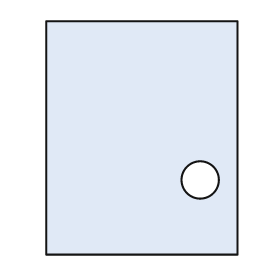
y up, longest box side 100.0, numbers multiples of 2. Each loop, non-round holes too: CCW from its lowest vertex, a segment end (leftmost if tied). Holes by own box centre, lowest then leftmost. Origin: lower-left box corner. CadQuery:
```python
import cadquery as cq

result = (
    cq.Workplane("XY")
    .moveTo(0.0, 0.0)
    .lineTo(82.0, 0.0)
    .lineTo(82.0, 100.0)
    .lineTo(0.0, 100.0)
    .close()
    .moveTo(66.0, 32.0)
    .circle(8.0)
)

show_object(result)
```